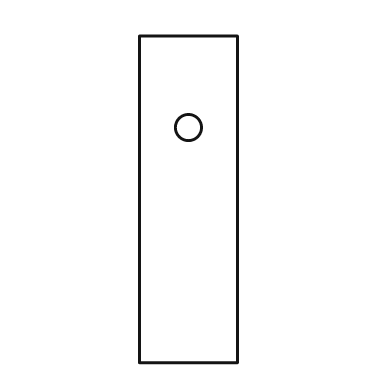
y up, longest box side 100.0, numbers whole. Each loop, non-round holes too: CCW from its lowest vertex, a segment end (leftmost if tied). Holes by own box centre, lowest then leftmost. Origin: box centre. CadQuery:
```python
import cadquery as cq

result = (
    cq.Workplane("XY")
    .moveTo(-15.0, -50.0)
    .lineTo(15.0, -50.0)
    .lineTo(15.0, 50.0)
    .lineTo(-15.0, 50.0)
    .close()
    .moveTo(0.0, 22.0)
    .circle(4.0)
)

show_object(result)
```